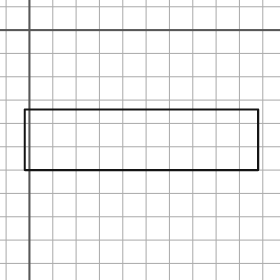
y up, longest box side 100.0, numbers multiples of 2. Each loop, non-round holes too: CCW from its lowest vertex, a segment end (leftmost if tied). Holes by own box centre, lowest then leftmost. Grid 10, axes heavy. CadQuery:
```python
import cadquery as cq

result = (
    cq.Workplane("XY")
    .moveTo(-2.0, -60.0)
    .lineTo(98.0, -60.0)
    .lineTo(98.0, -34.0)
    .lineTo(-2.0, -34.0)
    .close()
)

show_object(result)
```